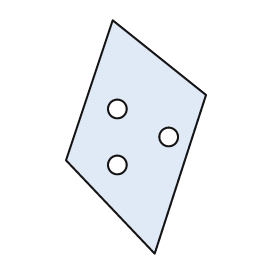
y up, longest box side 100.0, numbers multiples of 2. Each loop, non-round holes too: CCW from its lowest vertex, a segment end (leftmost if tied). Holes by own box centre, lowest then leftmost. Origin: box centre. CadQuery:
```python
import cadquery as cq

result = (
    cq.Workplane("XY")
    .moveTo(8.0, -50.0)
    .lineTo(30.0, 18.0)
    .lineTo(-10.0, 50.0)
    .lineTo(-30.0, -10.0)
    .close()
    .moveTo(-8.0, -12.0)
    .circle(4.0)
    .moveTo(14.0, 0.0)
    .circle(4.0)
    .moveTo(-8.0, 12.0)
    .circle(4.0)
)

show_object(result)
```